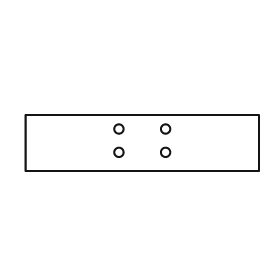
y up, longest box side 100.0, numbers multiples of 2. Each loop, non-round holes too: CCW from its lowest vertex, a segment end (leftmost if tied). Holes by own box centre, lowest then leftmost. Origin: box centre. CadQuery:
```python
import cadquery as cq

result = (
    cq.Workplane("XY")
    .moveTo(-50.0, -12.0)
    .lineTo(50.0, -12.0)
    .lineTo(50.0, 12.0)
    .lineTo(-50.0, 12.0)
    .close()
    .moveTo(-10.0, -4.0)
    .circle(2.0)
    .moveTo(10.0, -4.0)
    .circle(2.0)
    .moveTo(-10.0, 6.0)
    .circle(2.0)
    .moveTo(10.0, 6.0)
    .circle(2.0)
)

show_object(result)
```